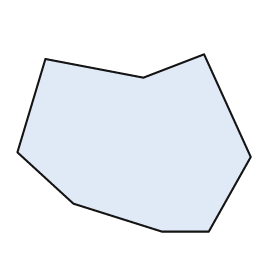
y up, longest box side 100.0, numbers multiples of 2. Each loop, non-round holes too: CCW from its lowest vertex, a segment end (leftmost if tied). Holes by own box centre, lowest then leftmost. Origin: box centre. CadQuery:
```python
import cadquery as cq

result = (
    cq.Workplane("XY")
    .moveTo(12.0, -38.0)
    .lineTo(32.0, -38.0)
    .lineTo(50.0, -6.0)
    .lineTo(30.0, 38.0)
    .lineTo(4.0, 28.0)
    .lineTo(-38.0, 36.0)
    .lineTo(-50.0, -4.0)
    .lineTo(-26.0, -26.0)
    .close()
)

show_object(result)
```